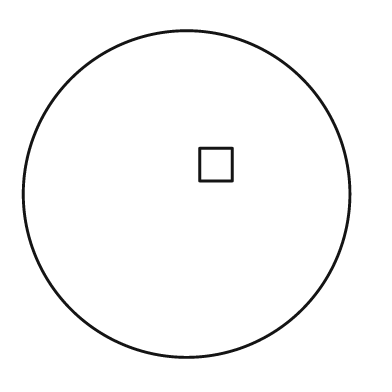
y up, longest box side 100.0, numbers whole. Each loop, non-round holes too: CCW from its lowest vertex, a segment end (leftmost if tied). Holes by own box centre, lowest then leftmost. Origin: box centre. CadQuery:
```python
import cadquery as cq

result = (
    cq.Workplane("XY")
    .moveTo(0.0, 0.0)
    .circle(50.0)
    .moveTo(4.0, 4.0)
    .lineTo(14.0, 4.0)
    .lineTo(14.0, 14.0)
    .lineTo(4.0, 14.0)
    .close()
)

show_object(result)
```